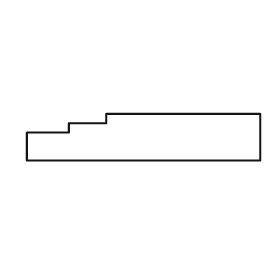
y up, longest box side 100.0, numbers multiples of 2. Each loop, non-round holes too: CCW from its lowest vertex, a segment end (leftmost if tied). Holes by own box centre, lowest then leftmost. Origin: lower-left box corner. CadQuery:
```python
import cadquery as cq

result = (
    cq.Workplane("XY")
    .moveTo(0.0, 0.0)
    .lineTo(100.0, 0.0)
    .lineTo(100.0, 20.0)
    .lineTo(34.0, 20.0)
    .lineTo(34.0, 16.0)
    .lineTo(18.0, 16.0)
    .lineTo(18.0, 12.0)
    .lineTo(0.0, 12.0)
    .close()
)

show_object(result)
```